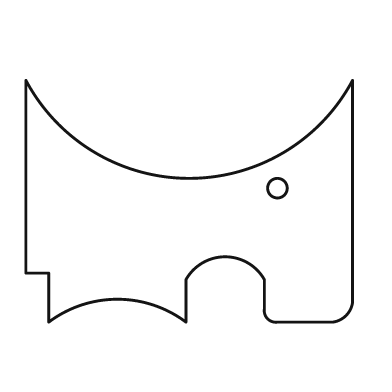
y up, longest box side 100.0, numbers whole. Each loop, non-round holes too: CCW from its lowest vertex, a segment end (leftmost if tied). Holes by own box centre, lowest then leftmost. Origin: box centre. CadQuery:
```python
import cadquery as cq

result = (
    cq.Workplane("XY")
    .moveTo(-43.0, -37.0)
    .threePointArc((-22.0, -30.0), (-1.0, -37.0))
    .lineTo(-1.0, -24.0)
    .threePointArc((11.0, -17.0), (23.0, -24.0))
    .lineTo(23.0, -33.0)
    .threePointArc((24.0, -36.0), (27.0, -37.0))
    .lineTo(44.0, -37.0)
    .threePointArc((48.0, -35.0), (50.0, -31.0))
    .lineTo(50.0, 37.0)
    .threePointArc((0.0, 7.0), (-50.0, 37.0))
    .lineTo(-50.0, -22.0)
    .lineTo(-43.0, -22.0)
    .close()
    .moveTo(27.0, 4.0)
    .circle(3.0)
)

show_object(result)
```